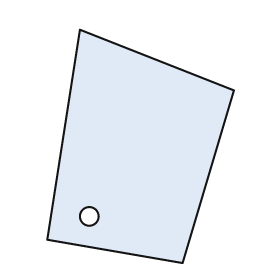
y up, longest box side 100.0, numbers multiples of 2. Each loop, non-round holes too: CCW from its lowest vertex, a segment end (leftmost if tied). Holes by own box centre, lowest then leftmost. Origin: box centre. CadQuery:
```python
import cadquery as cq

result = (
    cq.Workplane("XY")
    .moveTo(18.0, -50.0)
    .lineTo(40.0, 24.0)
    .lineTo(-26.0, 50.0)
    .lineTo(-40.0, -40.0)
    .close()
    .moveTo(-22.0, -30.0)
    .circle(4.0)
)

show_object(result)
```